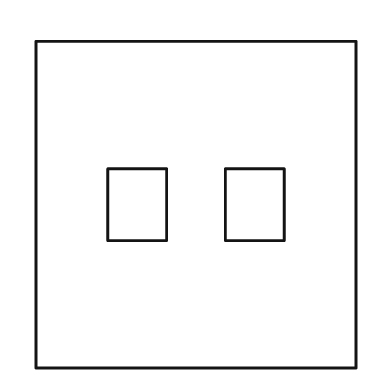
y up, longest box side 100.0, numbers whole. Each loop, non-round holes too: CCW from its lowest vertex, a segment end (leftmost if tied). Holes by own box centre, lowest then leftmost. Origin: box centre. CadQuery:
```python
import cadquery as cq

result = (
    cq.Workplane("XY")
    .moveTo(-49.0, -50.0)
    .lineTo(49.0, -50.0)
    .lineTo(49.0, 50.0)
    .lineTo(-49.0, 50.0)
    .close()
    .moveTo(-27.0, -11.0)
    .lineTo(-9.0, -11.0)
    .lineTo(-9.0, 11.0)
    .lineTo(-27.0, 11.0)
    .close()
    .moveTo(9.0, -11.0)
    .lineTo(27.0, -11.0)
    .lineTo(27.0, 11.0)
    .lineTo(9.0, 11.0)
    .close()
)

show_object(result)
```